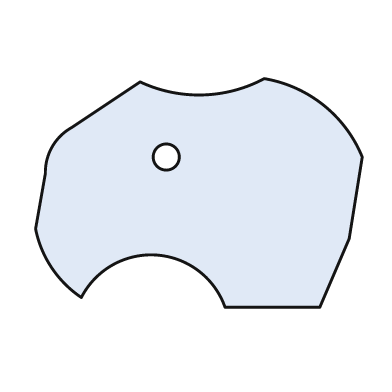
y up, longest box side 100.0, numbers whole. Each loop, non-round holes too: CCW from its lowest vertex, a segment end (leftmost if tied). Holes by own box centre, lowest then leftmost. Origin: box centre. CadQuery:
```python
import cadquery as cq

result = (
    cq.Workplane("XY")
    .moveTo(8.0, -35.0)
    .lineTo(37.0, -35.0)
    .lineTo(46.0, -14.0)
    .lineTo(50.0, 11.0)
    .threePointArc((38.0, 27.0), (20.0, 35.0))
    .threePointArc((1.0, 30.0), (-18.0, 34.0))
    .lineTo(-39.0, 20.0)
    .threePointArc((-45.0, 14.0), (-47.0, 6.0))
    .lineTo(-50.0, -11.0)
    .threePointArc((-45.0, -23.0), (-36.0, -32.0))
    .threePointArc((-13.0, -19.0), (8.0, -35.0))
    .close()
    .moveTo(-10.0, 11.0)
    .circle(4.0)
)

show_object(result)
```